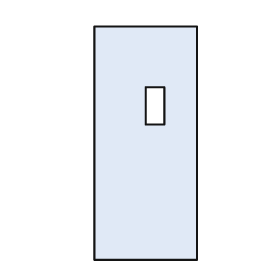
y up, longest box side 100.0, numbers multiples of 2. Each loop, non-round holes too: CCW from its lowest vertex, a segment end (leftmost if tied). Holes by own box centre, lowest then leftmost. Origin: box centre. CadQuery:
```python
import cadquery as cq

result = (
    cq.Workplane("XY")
    .moveTo(-22.0, -50.0)
    .lineTo(22.0, -50.0)
    .lineTo(22.0, 50.0)
    .lineTo(-22.0, 50.0)
    .close()
    .moveTo(0.0, 8.0)
    .lineTo(8.0, 8.0)
    .lineTo(8.0, 24.0)
    .lineTo(0.0, 24.0)
    .close()
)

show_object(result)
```